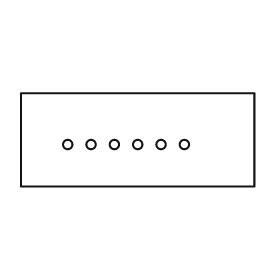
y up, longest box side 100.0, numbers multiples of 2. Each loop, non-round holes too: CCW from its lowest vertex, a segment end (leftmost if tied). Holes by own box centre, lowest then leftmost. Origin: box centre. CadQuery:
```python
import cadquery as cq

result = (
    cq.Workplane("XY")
    .moveTo(-50.0, -20.0)
    .lineTo(50.0, -20.0)
    .lineTo(50.0, 20.0)
    .lineTo(-50.0, 20.0)
    .close()
    .moveTo(-30.0, -2.0)
    .circle(2.0)
    .moveTo(-20.0, -2.0)
    .circle(2.0)
    .moveTo(-10.0, -2.0)
    .circle(2.0)
    .moveTo(0.0, -2.0)
    .circle(2.0)
    .moveTo(10.0, -2.0)
    .circle(2.0)
    .moveTo(20.0, -2.0)
    .circle(2.0)
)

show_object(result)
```